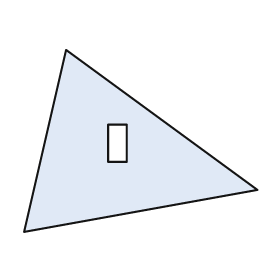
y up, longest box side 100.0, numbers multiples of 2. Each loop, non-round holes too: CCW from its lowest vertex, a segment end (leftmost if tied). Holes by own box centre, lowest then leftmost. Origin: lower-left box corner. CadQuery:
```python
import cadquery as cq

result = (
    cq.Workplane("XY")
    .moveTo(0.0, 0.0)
    .lineTo(100.0, 18.0)
    .lineTo(18.0, 78.0)
    .close()
    .moveTo(36.0, 30.0)
    .lineTo(44.0, 30.0)
    .lineTo(44.0, 46.0)
    .lineTo(36.0, 46.0)
    .close()
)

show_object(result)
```